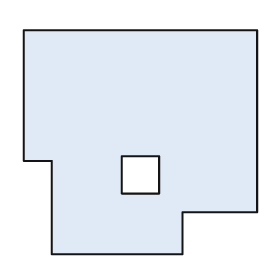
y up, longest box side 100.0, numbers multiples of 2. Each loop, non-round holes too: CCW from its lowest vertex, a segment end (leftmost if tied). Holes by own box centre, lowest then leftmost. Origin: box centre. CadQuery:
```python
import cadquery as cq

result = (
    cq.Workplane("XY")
    .moveTo(-38.0, -48.0)
    .lineTo(18.0, -48.0)
    .lineTo(18.0, -30.0)
    .lineTo(50.0, -30.0)
    .lineTo(50.0, 48.0)
    .lineTo(-50.0, 48.0)
    .lineTo(-50.0, -8.0)
    .lineTo(-38.0, -8.0)
    .close()
    .moveTo(-8.0, -22.0)
    .lineTo(8.0, -22.0)
    .lineTo(8.0, -6.0)
    .lineTo(-8.0, -6.0)
    .close()
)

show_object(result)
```